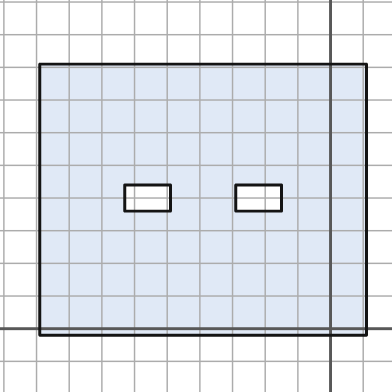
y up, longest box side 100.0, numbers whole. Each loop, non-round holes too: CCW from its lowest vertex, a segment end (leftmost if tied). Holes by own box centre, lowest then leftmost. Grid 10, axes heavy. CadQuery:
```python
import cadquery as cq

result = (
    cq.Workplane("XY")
    .moveTo(-89.0, -2.0)
    .lineTo(11.0, -2.0)
    .lineTo(11.0, 81.0)
    .lineTo(-89.0, 81.0)
    .close()
    .moveTo(-63.0, 36.0)
    .lineTo(-49.0, 36.0)
    .lineTo(-49.0, 44.0)
    .lineTo(-63.0, 44.0)
    .close()
    .moveTo(-29.0, 36.0)
    .lineTo(-15.0, 36.0)
    .lineTo(-15.0, 44.0)
    .lineTo(-29.0, 44.0)
    .close()
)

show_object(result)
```